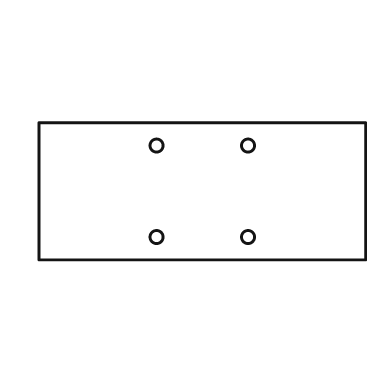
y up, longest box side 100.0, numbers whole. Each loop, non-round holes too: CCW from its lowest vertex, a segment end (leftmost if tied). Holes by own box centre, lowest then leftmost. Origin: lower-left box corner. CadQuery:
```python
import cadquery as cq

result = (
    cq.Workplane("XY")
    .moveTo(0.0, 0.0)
    .lineTo(100.0, 0.0)
    .lineTo(100.0, 42.0)
    .lineTo(0.0, 42.0)
    .close()
    .moveTo(36.0, 7.0)
    .circle(2.0)
    .moveTo(64.0, 7.0)
    .circle(2.0)
    .moveTo(36.0, 35.0)
    .circle(2.0)
    .moveTo(64.0, 35.0)
    .circle(2.0)
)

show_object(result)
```